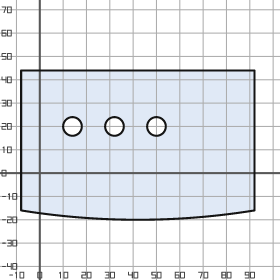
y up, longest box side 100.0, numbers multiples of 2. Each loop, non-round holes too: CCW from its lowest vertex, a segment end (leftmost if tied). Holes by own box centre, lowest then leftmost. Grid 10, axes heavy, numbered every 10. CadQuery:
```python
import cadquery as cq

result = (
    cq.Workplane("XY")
    .moveTo(-8.0, -16.0)
    .threePointArc((42.0, -20.0), (92.0, -16.0))
    .lineTo(92.0, 44.0)
    .lineTo(-8.0, 44.0)
    .close()
    .moveTo(14.0, 20.0)
    .circle(4.0)
    .moveTo(32.0, 20.0)
    .circle(4.0)
    .moveTo(50.0, 20.0)
    .circle(4.0)
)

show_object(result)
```